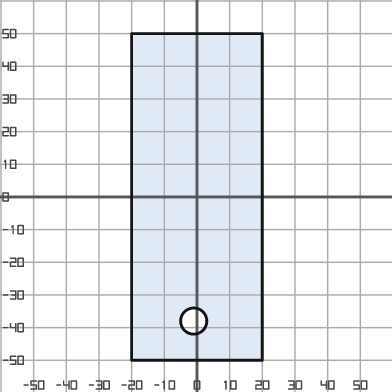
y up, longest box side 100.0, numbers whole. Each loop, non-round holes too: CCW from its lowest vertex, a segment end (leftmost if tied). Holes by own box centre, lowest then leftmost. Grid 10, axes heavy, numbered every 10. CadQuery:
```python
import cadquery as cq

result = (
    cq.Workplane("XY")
    .moveTo(-20.0, -50.0)
    .lineTo(20.0, -50.0)
    .lineTo(20.0, 50.0)
    .lineTo(-20.0, 50.0)
    .close()
    .moveTo(-1.0, -38.0)
    .circle(4.0)
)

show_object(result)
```